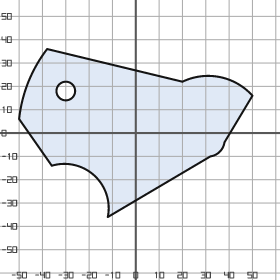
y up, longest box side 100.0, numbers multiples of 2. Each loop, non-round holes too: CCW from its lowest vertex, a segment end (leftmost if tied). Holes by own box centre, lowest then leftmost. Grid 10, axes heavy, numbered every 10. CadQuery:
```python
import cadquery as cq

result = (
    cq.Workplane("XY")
    .moveTo(-12.0, -36.0)
    .lineTo(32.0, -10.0)
    .threePointArc((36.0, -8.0), (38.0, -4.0))
    .lineTo(50.0, 16.0)
    .threePointArc((36.0, 24.0), (20.0, 22.0))
    .lineTo(-38.0, 36.0)
    .threePointArc((-46.0, 22.0), (-50.0, 6.0))
    .lineTo(-36.0, -14.0)
    .threePointArc((-18.0, -18.0), (-12.0, -36.0))
    .close()
    .moveTo(-30.0, 18.0)
    .circle(4.0)
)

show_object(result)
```